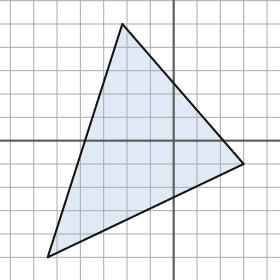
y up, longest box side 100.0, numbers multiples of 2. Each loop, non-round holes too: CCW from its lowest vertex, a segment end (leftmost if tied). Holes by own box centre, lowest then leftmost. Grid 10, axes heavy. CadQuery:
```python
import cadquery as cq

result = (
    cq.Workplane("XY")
    .moveTo(-54.0, -50.0)
    .lineTo(30.0, -10.0)
    .lineTo(-22.0, 50.0)
    .close()
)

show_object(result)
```